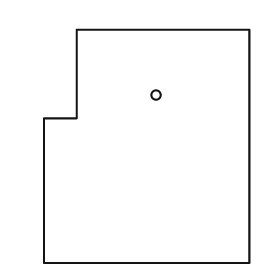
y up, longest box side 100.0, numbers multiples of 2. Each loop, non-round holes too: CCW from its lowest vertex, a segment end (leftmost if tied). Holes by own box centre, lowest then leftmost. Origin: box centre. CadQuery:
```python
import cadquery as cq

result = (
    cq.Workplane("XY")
    .moveTo(-44.0, -50.0)
    .lineTo(44.0, -50.0)
    .lineTo(44.0, 50.0)
    .lineTo(-30.0, 50.0)
    .lineTo(-30.0, 12.0)
    .lineTo(-44.0, 12.0)
    .close()
    .moveTo(4.0, 22.0)
    .circle(2.0)
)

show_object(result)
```